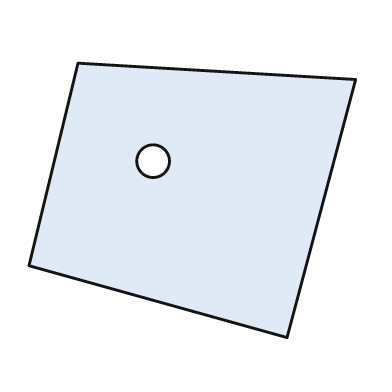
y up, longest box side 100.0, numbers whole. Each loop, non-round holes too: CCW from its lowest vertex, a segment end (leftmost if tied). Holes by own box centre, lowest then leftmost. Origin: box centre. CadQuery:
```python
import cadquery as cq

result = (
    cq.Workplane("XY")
    .moveTo(29.0, -42.0)
    .lineTo(50.0, 37.0)
    .lineTo(-35.0, 42.0)
    .lineTo(-50.0, -20.0)
    .close()
    .moveTo(-12.0, 12.0)
    .circle(5.0)
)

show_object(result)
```